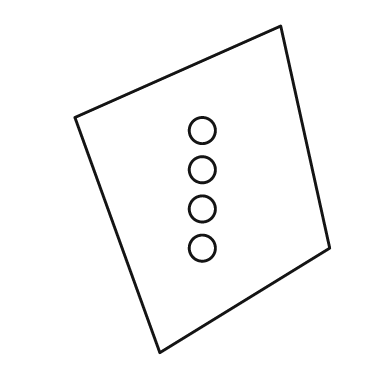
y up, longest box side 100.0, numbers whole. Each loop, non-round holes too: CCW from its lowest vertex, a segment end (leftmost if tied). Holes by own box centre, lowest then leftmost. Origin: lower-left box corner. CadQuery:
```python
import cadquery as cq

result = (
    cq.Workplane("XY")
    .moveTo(26.0, 0.0)
    .lineTo(78.0, 32.0)
    .lineTo(63.0, 100.0)
    .lineTo(0.0, 72.0)
    .close()
    .moveTo(39.0, 32.0)
    .circle(4.0)
    .moveTo(39.0, 44.0)
    .circle(4.0)
    .moveTo(39.0, 56.0)
    .circle(4.0)
    .moveTo(39.0, 68.0)
    .circle(4.0)
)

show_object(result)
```